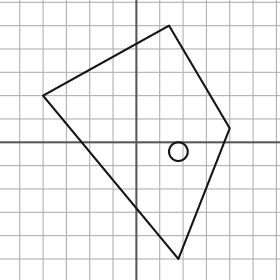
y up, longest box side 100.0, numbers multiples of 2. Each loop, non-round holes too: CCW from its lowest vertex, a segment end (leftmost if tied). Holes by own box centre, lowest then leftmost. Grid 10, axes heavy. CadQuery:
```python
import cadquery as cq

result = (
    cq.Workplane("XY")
    .moveTo(18.0, -50.0)
    .lineTo(40.0, 6.0)
    .lineTo(14.0, 50.0)
    .lineTo(-40.0, 20.0)
    .close()
    .moveTo(18.0, -4.0)
    .circle(4.0)
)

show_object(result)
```